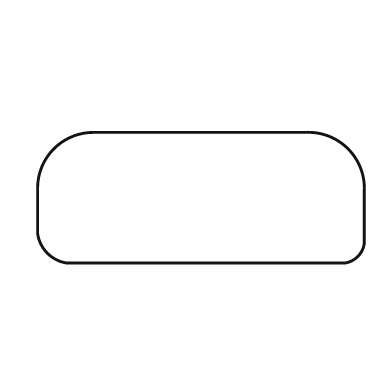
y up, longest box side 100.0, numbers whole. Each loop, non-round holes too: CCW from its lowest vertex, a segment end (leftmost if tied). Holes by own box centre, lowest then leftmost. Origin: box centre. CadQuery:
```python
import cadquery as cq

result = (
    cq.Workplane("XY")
    .moveTo(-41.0, -20.0)
    .lineTo(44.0, -20.0)
    .threePointArc((48.0, -18.0), (50.0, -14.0))
    .lineTo(50.0, 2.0)
    .threePointArc((45.0, 15.0), (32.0, 20.0))
    .lineTo(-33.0, 20.0)
    .threePointArc((-45.0, 15.0), (-50.0, 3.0))
    .lineTo(-50.0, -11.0)
    .threePointArc((-47.0, -17.0), (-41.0, -20.0))
    .close()
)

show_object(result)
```